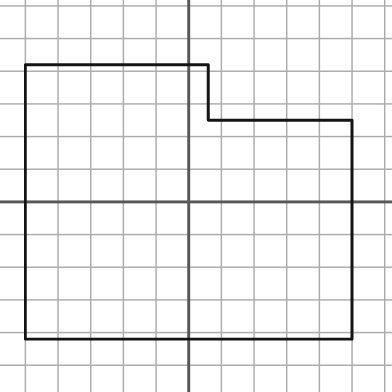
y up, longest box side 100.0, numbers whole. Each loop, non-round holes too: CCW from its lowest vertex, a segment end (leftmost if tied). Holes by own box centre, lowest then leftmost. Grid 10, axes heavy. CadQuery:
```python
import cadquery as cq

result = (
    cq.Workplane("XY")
    .moveTo(-50.0, -42.0)
    .lineTo(50.0, -42.0)
    .lineTo(50.0, 25.0)
    .lineTo(6.0, 25.0)
    .lineTo(6.0, 42.0)
    .lineTo(-50.0, 42.0)
    .close()
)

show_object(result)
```